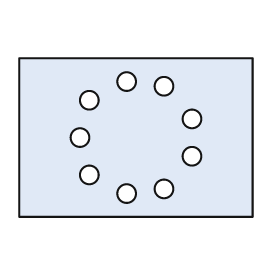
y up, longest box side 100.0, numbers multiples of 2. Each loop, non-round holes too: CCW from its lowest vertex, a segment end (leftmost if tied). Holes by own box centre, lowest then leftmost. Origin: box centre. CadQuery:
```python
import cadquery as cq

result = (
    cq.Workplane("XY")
    .moveTo(-50.0, -34.0)
    .lineTo(50.0, -34.0)
    .lineTo(50.0, 34.0)
    .lineTo(-50.0, 34.0)
    .close()
    .moveTo(-4.0, -24.0)
    .circle(4.0)
    .moveTo(12.0, -22.0)
    .circle(4.0)
    .moveTo(-20.0, -16.0)
    .circle(4.0)
    .moveTo(24.0, -8.0)
    .circle(4.0)
    .moveTo(-24.0, 0.0)
    .circle(4.0)
    .moveTo(24.0, 8.0)
    .circle(4.0)
    .moveTo(-20.0, 16.0)
    .circle(4.0)
    .moveTo(12.0, 22.0)
    .circle(4.0)
    .moveTo(-4.0, 24.0)
    .circle(4.0)
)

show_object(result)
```